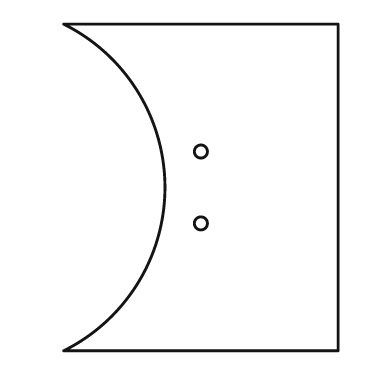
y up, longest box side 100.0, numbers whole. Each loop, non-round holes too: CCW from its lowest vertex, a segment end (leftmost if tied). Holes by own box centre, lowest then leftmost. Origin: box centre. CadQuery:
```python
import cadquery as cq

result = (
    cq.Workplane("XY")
    .moveTo(-42.0, -50.0)
    .lineTo(42.0, -50.0)
    .lineTo(42.0, 50.0)
    .lineTo(-42.0, 50.0)
    .threePointArc((-11.0, 0.0), (-42.0, -50.0))
    .close()
    .moveTo(0.0, -11.0)
    .circle(2.0)
    .moveTo(0.0, 11.0)
    .circle(2.0)
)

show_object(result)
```